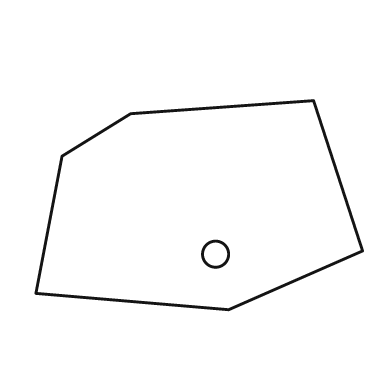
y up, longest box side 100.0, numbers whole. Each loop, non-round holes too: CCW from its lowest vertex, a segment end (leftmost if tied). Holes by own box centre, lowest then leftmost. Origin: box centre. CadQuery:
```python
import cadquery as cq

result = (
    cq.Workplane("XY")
    .moveTo(9.0, -32.0)
    .lineTo(50.0, -14.0)
    .lineTo(35.0, 32.0)
    .lineTo(-21.0, 28.0)
    .lineTo(-42.0, 15.0)
    .lineTo(-50.0, -27.0)
    .close()
    .moveTo(5.0, -15.0)
    .circle(4.0)
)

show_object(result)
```